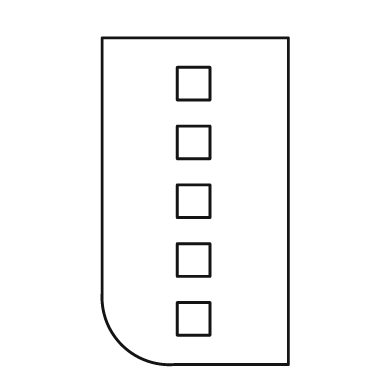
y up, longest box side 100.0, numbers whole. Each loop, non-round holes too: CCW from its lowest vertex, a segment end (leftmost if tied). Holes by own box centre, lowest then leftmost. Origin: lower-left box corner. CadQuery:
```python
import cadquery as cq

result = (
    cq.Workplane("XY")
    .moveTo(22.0, 0.0)
    .lineTo(57.0, 0.0)
    .lineTo(57.0, 100.0)
    .lineTo(0.0, 100.0)
    .lineTo(0.0, 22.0)
    .threePointArc((6.0, 6.0), (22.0, 0.0))
    .close()
    .moveTo(23.0, 9.0)
    .lineTo(33.0, 9.0)
    .lineTo(33.0, 19.0)
    .lineTo(23.0, 19.0)
    .close()
    .moveTo(23.0, 27.0)
    .lineTo(33.0, 27.0)
    .lineTo(33.0, 37.0)
    .lineTo(23.0, 37.0)
    .close()
    .moveTo(23.0, 45.0)
    .lineTo(33.0, 45.0)
    .lineTo(33.0, 55.0)
    .lineTo(23.0, 55.0)
    .close()
    .moveTo(23.0, 63.0)
    .lineTo(33.0, 63.0)
    .lineTo(33.0, 73.0)
    .lineTo(23.0, 73.0)
    .close()
    .moveTo(23.0, 81.0)
    .lineTo(33.0, 81.0)
    .lineTo(33.0, 91.0)
    .lineTo(23.0, 91.0)
    .close()
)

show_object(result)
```